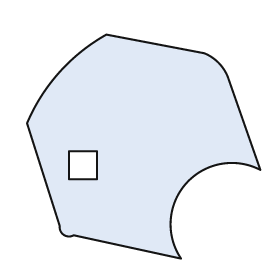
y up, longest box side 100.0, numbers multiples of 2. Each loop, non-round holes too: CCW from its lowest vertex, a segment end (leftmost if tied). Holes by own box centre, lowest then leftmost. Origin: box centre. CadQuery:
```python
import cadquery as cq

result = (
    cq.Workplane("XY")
    .moveTo(16.0, -48.0)
    .threePointArc((18.0, -16.0), (50.0, -10.0))
    .lineTo(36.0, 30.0)
    .threePointArc((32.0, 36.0), (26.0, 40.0))
    .lineTo(-16.0, 48.0)
    .threePointArc((-36.0, 32.0), (-50.0, 10.0))
    .lineTo(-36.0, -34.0)
    .threePointArc((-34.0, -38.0), (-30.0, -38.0))
    .close()
    .moveTo(-32.0, -14.0)
    .lineTo(-20.0, -14.0)
    .lineTo(-20.0, -2.0)
    .lineTo(-32.0, -2.0)
    .close()
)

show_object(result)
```